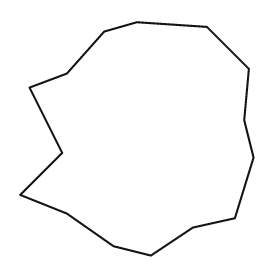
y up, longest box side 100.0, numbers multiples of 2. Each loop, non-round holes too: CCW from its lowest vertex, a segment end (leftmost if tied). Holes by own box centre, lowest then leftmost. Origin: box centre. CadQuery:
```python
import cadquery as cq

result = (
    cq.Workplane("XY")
    .moveTo(6.0, -50.0)
    .lineTo(24.0, -38.0)
    .lineTo(42.0, -34.0)
    .lineTo(50.0, -8.0)
    .lineTo(46.0, 8.0)
    .lineTo(48.0, 30.0)
    .lineTo(30.0, 48.0)
    .lineTo(0.0, 50.0)
    .lineTo(-14.0, 46.0)
    .lineTo(-30.0, 28.0)
    .lineTo(-46.0, 22.0)
    .lineTo(-32.0, -6.0)
    .lineTo(-50.0, -24.0)
    .lineTo(-30.0, -32.0)
    .lineTo(-10.0, -46.0)
    .close()
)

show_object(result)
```